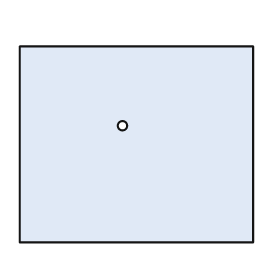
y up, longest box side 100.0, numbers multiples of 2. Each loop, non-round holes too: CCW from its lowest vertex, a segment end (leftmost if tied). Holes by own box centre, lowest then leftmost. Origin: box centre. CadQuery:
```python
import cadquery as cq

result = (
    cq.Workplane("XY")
    .moveTo(-50.0, -42.0)
    .lineTo(50.0, -42.0)
    .lineTo(50.0, 42.0)
    .lineTo(-50.0, 42.0)
    .close()
    .moveTo(-6.0, 8.0)
    .circle(2.0)
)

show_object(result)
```